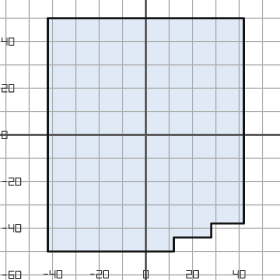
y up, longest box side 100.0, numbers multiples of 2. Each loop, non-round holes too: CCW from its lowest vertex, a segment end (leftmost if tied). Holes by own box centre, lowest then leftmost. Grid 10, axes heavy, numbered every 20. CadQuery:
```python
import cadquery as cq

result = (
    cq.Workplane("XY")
    .moveTo(-42.0, -50.0)
    .lineTo(12.0, -50.0)
    .lineTo(12.0, -44.0)
    .lineTo(28.0, -44.0)
    .lineTo(28.0, -38.0)
    .lineTo(42.0, -38.0)
    .lineTo(42.0, 50.0)
    .lineTo(-42.0, 50.0)
    .close()
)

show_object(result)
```